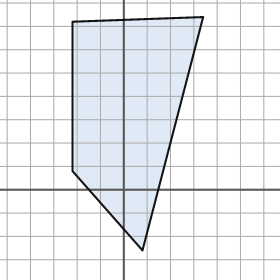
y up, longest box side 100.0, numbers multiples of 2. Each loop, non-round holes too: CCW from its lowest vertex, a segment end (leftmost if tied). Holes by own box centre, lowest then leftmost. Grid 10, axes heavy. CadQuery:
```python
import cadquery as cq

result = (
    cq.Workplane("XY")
    .moveTo(8.0, -26.0)
    .lineTo(34.0, 74.0)
    .lineTo(-22.0, 72.0)
    .lineTo(-22.0, 8.0)
    .close()
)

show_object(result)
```